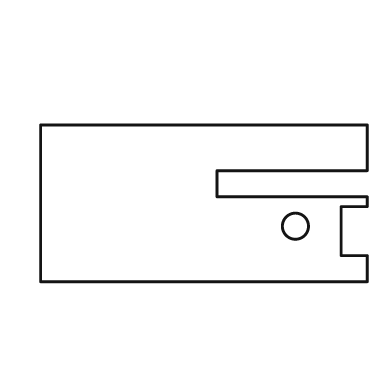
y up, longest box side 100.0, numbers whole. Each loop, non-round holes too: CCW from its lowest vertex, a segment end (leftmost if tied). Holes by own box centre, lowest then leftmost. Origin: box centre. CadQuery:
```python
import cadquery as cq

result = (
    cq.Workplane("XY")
    .moveTo(-50.0, -24.0)
    .lineTo(50.0, -24.0)
    .lineTo(50.0, -16.0)
    .lineTo(42.0, -16.0)
    .lineTo(42.0, -1.0)
    .lineTo(50.0, -1.0)
    .lineTo(50.0, 2.0)
    .lineTo(4.0, 2.0)
    .lineTo(4.0, 10.0)
    .lineTo(50.0, 10.0)
    .lineTo(50.0, 24.0)
    .lineTo(-50.0, 24.0)
    .close()
    .moveTo(28.0, -7.0)
    .circle(4.0)
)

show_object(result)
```